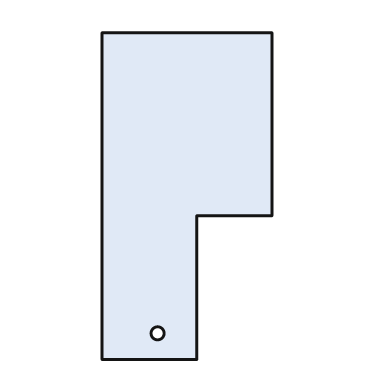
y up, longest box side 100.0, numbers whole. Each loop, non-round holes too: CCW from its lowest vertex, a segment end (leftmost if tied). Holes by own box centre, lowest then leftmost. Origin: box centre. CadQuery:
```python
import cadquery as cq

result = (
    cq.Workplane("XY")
    .moveTo(-26.0, -50.0)
    .lineTo(3.0, -50.0)
    .lineTo(3.0, -6.0)
    .lineTo(26.0, -6.0)
    .lineTo(26.0, 50.0)
    .lineTo(-26.0, 50.0)
    .close()
    .moveTo(-9.0, -42.0)
    .circle(2.0)
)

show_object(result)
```